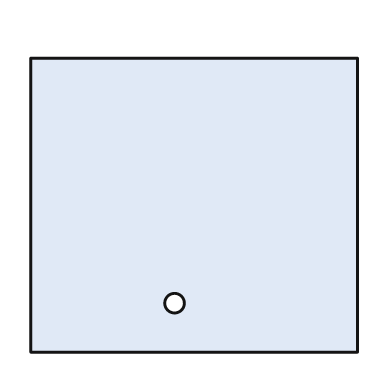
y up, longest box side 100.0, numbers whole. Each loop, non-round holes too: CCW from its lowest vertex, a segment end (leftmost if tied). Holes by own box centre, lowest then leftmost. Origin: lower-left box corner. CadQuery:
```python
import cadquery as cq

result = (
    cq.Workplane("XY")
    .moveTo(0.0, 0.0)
    .lineTo(100.0, 0.0)
    .lineTo(100.0, 90.0)
    .lineTo(0.0, 90.0)
    .close()
    .moveTo(44.0, 15.0)
    .circle(3.0)
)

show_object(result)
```